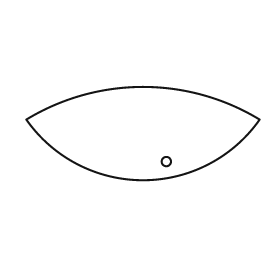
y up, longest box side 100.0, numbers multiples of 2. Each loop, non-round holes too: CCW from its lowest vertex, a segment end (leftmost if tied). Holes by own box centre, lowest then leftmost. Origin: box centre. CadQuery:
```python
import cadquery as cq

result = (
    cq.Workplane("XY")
    .moveTo(-50.0, 6.0)
    .threePointArc((0.0, -20.0), (50.0, 6.0))
    .threePointArc((0.0, 20.0), (-50.0, 6.0))
    .close()
    .moveTo(10.0, -12.0)
    .circle(2.0)
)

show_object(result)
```